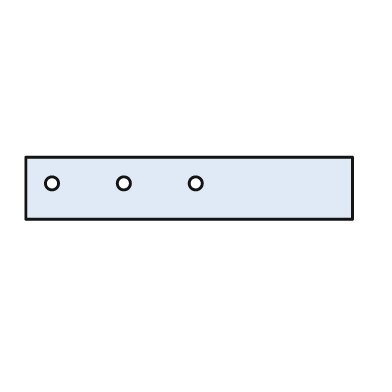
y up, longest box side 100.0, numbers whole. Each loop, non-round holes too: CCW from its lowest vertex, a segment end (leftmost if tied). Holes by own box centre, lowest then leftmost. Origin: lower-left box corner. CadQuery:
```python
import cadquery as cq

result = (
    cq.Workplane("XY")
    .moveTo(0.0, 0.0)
    .lineTo(100.0, 0.0)
    .lineTo(100.0, 19.0)
    .lineTo(0.0, 19.0)
    .close()
    .moveTo(8.0, 11.0)
    .circle(2.0)
    .moveTo(30.0, 11.0)
    .circle(2.0)
    .moveTo(52.0, 11.0)
    .circle(2.0)
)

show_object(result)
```